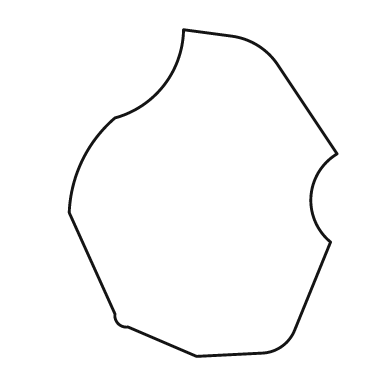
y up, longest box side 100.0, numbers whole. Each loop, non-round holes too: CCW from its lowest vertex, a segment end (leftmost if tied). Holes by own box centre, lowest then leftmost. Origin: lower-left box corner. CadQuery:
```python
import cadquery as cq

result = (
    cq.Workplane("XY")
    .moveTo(39.0, 0.0)
    .lineTo(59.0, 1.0)
    .threePointArc((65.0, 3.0), (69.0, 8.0))
    .lineTo(80.0, 35.0)
    .threePointArc((74.0, 49.0), (82.0, 62.0))
    .lineTo(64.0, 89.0)
    .threePointArc((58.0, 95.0), (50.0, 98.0))
    .lineTo(35.0, 100.0)
    .threePointArc((29.0, 83.0), (14.0, 73.0))
    .threePointArc((4.0, 60.0), (0.0, 44.0))
    .lineTo(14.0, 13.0)
    .threePointArc((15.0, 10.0), (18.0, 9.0))
    .close()
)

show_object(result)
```